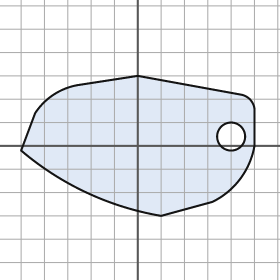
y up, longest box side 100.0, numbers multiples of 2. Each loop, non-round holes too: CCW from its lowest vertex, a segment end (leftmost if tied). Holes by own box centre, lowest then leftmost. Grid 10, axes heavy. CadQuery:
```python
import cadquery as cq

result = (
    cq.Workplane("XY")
    .moveTo(10.0, -30.0)
    .lineTo(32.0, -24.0)
    .threePointArc((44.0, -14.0), (50.0, 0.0))
    .lineTo(50.0, 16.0)
    .threePointArc((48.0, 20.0), (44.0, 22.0))
    .lineTo(0.0, 30.0)
    .lineTo(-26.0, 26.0)
    .threePointArc((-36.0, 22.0), (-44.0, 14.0))
    .lineTo(-50.0, -2.0)
    .threePointArc((-22.0, -20.0), (10.0, -30.0))
    .close()
    .moveTo(40.0, 4.0)
    .circle(6.0)
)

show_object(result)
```